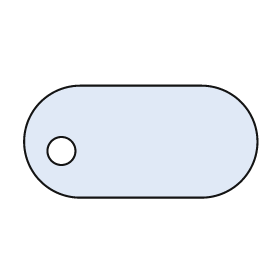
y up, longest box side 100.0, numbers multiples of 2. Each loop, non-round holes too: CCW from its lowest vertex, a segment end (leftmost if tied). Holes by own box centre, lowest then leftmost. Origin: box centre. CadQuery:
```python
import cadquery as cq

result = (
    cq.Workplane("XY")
    .moveTo(-26.0, -24.0)
    .lineTo(26.0, -24.0)
    .threePointArc((50.0, 0.0), (26.0, 24.0))
    .lineTo(-26.0, 24.0)
    .threePointArc((-50.0, 0.0), (-26.0, -24.0))
    .close()
    .moveTo(-34.0, -4.0)
    .circle(6.0)
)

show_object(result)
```